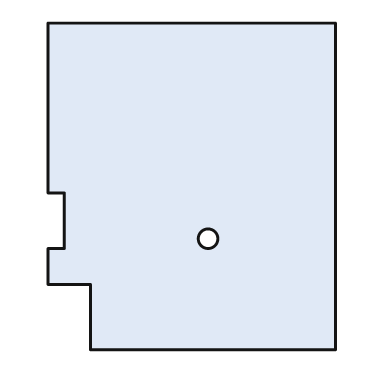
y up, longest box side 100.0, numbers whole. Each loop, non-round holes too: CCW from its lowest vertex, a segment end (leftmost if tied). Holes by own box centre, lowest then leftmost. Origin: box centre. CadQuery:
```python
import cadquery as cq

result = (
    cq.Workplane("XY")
    .moveTo(-31.0, -50.0)
    .lineTo(44.0, -50.0)
    .lineTo(44.0, 50.0)
    .lineTo(-44.0, 50.0)
    .lineTo(-44.0, -2.0)
    .lineTo(-39.0, -2.0)
    .lineTo(-39.0, -19.0)
    .lineTo(-44.0, -19.0)
    .lineTo(-44.0, -30.0)
    .lineTo(-31.0, -30.0)
    .close()
    .moveTo(5.0, -16.0)
    .circle(3.0)
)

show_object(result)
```